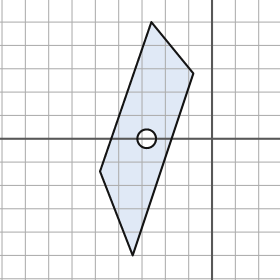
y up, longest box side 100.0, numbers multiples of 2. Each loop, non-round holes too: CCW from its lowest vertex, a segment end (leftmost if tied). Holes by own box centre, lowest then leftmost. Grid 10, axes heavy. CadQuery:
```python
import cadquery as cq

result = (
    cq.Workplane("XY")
    .moveTo(-34.0, -50.0)
    .lineTo(-8.0, 28.0)
    .lineTo(-26.0, 50.0)
    .lineTo(-48.0, -14.0)
    .close()
    .moveTo(-28.0, 0.0)
    .circle(4.0)
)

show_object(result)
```